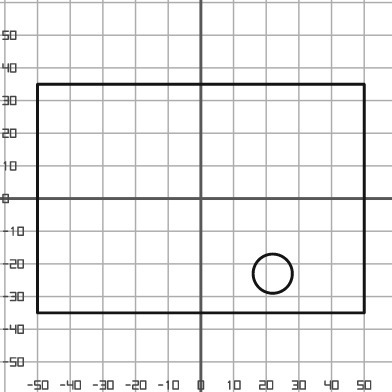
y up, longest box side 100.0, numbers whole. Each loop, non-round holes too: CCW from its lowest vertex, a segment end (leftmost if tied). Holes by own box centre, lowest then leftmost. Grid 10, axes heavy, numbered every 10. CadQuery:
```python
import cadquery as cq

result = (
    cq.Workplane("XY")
    .moveTo(-50.0, -35.0)
    .lineTo(50.0, -35.0)
    .lineTo(50.0, 35.0)
    .lineTo(-50.0, 35.0)
    .close()
    .moveTo(22.0, -23.0)
    .circle(6.0)
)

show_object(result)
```